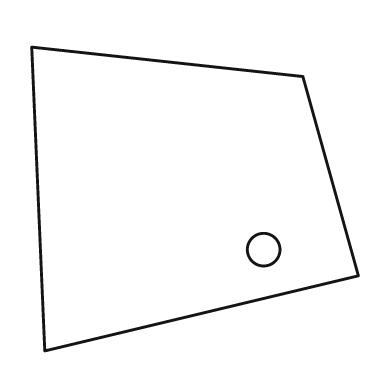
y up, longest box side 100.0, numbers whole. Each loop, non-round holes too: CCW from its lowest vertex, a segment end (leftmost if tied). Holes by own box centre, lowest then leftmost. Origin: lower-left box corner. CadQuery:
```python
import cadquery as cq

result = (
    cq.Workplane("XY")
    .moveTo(4.0, 0.0)
    .lineTo(100.0, 23.0)
    .lineTo(83.0, 84.0)
    .lineTo(0.0, 93.0)
    .close()
    .moveTo(71.0, 31.0)
    .circle(5.0)
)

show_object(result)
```